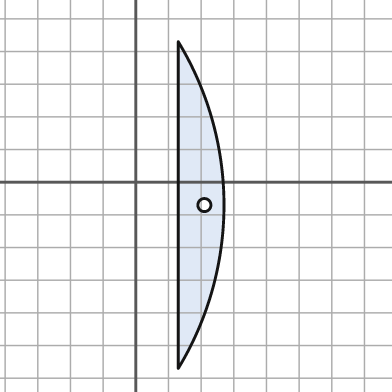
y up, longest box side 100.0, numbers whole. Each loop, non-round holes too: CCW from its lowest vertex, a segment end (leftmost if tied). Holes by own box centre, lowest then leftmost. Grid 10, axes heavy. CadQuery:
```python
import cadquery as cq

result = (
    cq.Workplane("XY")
    .moveTo(13.0, -57.0)
    .threePointArc((27.0, -7.0), (13.0, 43.0))
    .close()
    .moveTo(21.0, -7.0)
    .circle(2.0)
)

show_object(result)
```